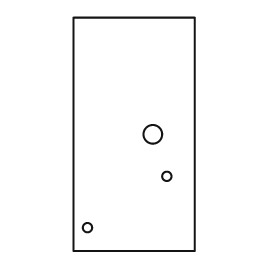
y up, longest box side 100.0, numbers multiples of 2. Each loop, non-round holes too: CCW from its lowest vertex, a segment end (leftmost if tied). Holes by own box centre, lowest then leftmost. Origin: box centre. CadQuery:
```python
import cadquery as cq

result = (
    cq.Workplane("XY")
    .moveTo(-26.0, -50.0)
    .lineTo(26.0, -50.0)
    .lineTo(26.0, 50.0)
    .lineTo(-26.0, 50.0)
    .close()
    .moveTo(-20.0, -40.0)
    .circle(2.0)
    .moveTo(14.0, -18.0)
    .circle(2.0)
    .moveTo(8.0, 0.0)
    .circle(4.0)
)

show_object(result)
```